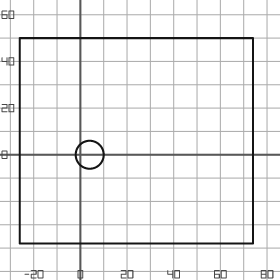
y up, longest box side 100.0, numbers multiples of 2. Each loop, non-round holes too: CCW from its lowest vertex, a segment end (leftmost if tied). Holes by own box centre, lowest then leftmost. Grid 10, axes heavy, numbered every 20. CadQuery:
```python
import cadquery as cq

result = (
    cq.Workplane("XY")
    .moveTo(-26.0, -38.0)
    .lineTo(74.0, -38.0)
    .lineTo(74.0, 50.0)
    .lineTo(-26.0, 50.0)
    .close()
    .moveTo(4.0, 0.0)
    .circle(6.0)
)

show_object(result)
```